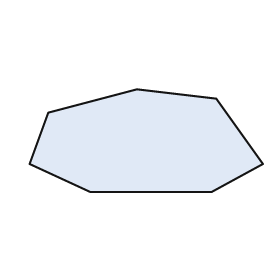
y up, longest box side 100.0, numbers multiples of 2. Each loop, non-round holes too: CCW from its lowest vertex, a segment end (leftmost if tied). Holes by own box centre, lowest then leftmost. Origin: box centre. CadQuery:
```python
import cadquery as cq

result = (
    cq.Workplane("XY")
    .moveTo(-24.0, -22.0)
    .lineTo(28.0, -22.0)
    .lineTo(50.0, -10.0)
    .lineTo(30.0, 18.0)
    .lineTo(-4.0, 22.0)
    .lineTo(-42.0, 12.0)
    .lineTo(-50.0, -10.0)
    .close()
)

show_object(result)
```